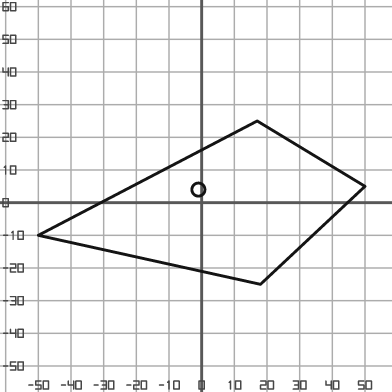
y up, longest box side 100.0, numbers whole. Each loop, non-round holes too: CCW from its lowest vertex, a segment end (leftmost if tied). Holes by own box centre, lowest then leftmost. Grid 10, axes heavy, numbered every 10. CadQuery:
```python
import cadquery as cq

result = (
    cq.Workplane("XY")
    .moveTo(18.0, -25.0)
    .lineTo(50.0, 5.0)
    .lineTo(17.0, 25.0)
    .lineTo(-50.0, -10.0)
    .close()
    .moveTo(-1.0, 4.0)
    .circle(2.0)
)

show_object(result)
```